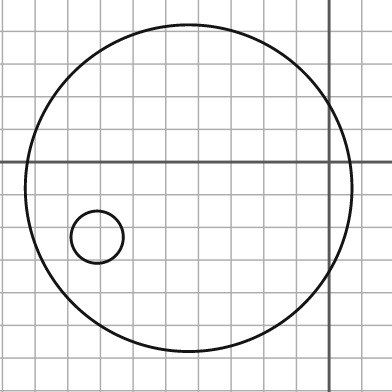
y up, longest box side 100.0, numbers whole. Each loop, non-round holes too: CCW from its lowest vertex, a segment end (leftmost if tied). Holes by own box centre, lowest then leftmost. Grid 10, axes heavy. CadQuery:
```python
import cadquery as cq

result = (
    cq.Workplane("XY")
    .moveTo(-43.0, -8.0)
    .circle(50.0)
    .moveTo(-71.0, -23.0)
    .circle(8.0)
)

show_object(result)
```